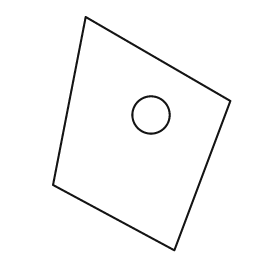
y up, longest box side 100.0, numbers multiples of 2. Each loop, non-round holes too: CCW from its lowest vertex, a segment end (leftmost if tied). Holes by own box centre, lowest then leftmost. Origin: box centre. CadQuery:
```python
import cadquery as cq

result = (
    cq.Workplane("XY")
    .moveTo(14.0, -50.0)
    .lineTo(38.0, 14.0)
    .lineTo(-24.0, 50.0)
    .lineTo(-38.0, -22.0)
    .close()
    .moveTo(4.0, 8.0)
    .circle(8.0)
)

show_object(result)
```